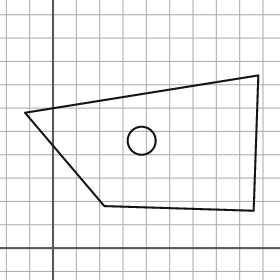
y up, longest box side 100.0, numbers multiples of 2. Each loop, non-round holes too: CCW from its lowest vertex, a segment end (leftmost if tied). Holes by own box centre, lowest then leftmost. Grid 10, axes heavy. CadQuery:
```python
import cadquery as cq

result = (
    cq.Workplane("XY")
    .moveTo(86.0, 16.0)
    .lineTo(88.0, 74.0)
    .lineTo(-12.0, 58.0)
    .lineTo(22.0, 18.0)
    .close()
    .moveTo(38.0, 46.0)
    .circle(6.0)
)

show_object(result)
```